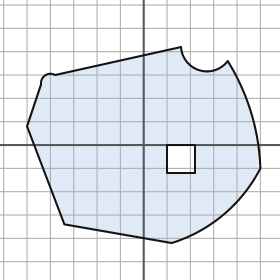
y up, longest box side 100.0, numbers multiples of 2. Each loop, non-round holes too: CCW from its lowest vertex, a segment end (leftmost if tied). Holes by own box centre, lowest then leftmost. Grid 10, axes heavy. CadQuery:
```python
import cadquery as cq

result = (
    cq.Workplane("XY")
    .moveTo(12.0, -42.0)
    .threePointArc((34.0, -30.0), (50.0, -10.0))
    .threePointArc((46.0, 14.0), (36.0, 36.0))
    .threePointArc((24.0, 32.0), (16.0, 42.0))
    .lineTo(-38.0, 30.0)
    .threePointArc((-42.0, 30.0), (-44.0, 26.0))
    .lineTo(-50.0, 8.0)
    .lineTo(-34.0, -34.0)
    .close()
    .moveTo(10.0, -12.0)
    .lineTo(22.0, -12.0)
    .lineTo(22.0, 0.0)
    .lineTo(10.0, 0.0)
    .close()
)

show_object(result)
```